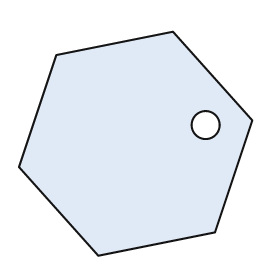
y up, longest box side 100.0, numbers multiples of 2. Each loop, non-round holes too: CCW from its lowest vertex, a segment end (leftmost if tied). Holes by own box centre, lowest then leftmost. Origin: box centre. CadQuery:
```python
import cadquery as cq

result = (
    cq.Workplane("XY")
    .moveTo(-16.0, -48.0)
    .lineTo(34.0, -38.0)
    .lineTo(50.0, 10.0)
    .lineTo(16.0, 48.0)
    .lineTo(-34.0, 38.0)
    .lineTo(-50.0, -10.0)
    .close()
    .moveTo(30.0, 8.0)
    .circle(6.0)
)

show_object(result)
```